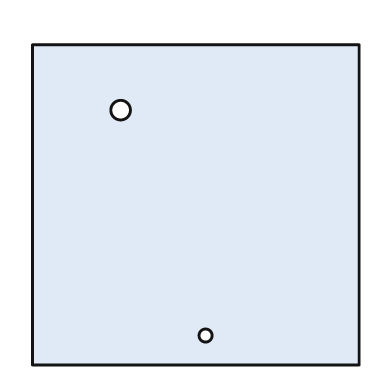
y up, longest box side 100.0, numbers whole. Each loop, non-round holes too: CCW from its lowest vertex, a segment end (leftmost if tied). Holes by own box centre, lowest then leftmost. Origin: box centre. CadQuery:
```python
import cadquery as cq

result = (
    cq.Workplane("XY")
    .moveTo(-50.0, -49.0)
    .lineTo(50.0, -49.0)
    .lineTo(50.0, 49.0)
    .lineTo(-50.0, 49.0)
    .close()
    .moveTo(3.0, -40.0)
    .circle(2.0)
    .moveTo(-23.0, 29.0)
    .circle(3.0)
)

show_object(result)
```